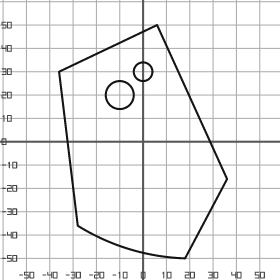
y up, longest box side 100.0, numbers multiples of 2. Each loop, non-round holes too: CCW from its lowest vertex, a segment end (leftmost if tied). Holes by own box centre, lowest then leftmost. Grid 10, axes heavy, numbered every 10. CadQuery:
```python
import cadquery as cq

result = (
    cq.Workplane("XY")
    .moveTo(18.0, -50.0)
    .lineTo(36.0, -16.0)
    .lineTo(6.0, 50.0)
    .lineTo(-36.0, 30.0)
    .lineTo(-28.0, -36.0)
    .threePointArc((-6.0, -46.0), (18.0, -50.0))
    .close()
    .moveTo(-10.0, 20.0)
    .circle(6.0)
    .moveTo(0.0, 30.0)
    .circle(4.0)
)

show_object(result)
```